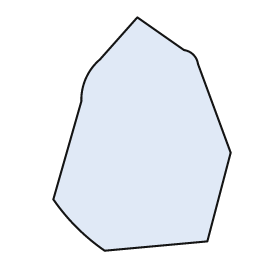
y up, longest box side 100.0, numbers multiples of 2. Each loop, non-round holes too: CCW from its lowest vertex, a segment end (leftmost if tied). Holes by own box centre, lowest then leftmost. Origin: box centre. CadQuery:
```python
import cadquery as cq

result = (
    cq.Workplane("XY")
    .moveTo(-16.0, -50.0)
    .lineTo(28.0, -46.0)
    .lineTo(38.0, -8.0)
    .lineTo(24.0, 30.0)
    .threePointArc((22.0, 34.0), (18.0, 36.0))
    .lineTo(-2.0, 50.0)
    .lineTo(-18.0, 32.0)
    .threePointArc((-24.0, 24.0), (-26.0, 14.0))
    .lineTo(-38.0, -28.0)
    .threePointArc((-28.0, -40.0), (-16.0, -50.0))
    .close()
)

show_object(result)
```